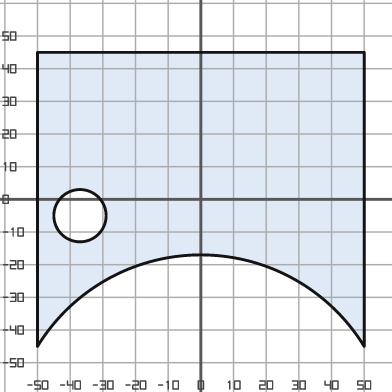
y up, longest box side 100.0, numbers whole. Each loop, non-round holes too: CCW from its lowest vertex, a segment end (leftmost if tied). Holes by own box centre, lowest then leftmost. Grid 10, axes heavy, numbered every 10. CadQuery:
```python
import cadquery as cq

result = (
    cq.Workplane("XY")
    .moveTo(-50.0, -45.0)
    .threePointArc((0.0, -17.0), (50.0, -45.0))
    .lineTo(50.0, 45.0)
    .lineTo(-50.0, 45.0)
    .close()
    .moveTo(-37.0, -5.0)
    .circle(8.0)
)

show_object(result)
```